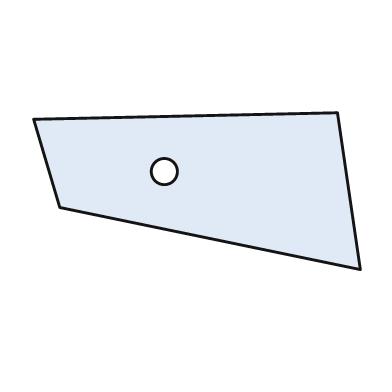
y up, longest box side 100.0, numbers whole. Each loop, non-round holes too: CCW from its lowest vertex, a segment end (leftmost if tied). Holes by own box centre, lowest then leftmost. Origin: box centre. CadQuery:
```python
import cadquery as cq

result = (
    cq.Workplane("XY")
    .moveTo(50.0, -24.0)
    .lineTo(43.0, 24.0)
    .lineTo(-50.0, 22.0)
    .lineTo(-42.0, -5.0)
    .close()
    .moveTo(-10.0, 6.0)
    .circle(4.0)
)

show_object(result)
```